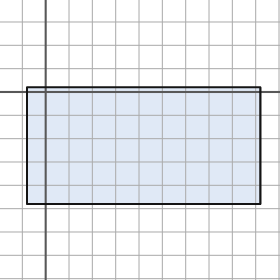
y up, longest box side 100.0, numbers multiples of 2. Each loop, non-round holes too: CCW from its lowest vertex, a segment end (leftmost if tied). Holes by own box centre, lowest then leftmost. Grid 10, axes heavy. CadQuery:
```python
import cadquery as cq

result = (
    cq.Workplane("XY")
    .moveTo(-8.0, -48.0)
    .lineTo(92.0, -48.0)
    .lineTo(92.0, 2.0)
    .lineTo(-8.0, 2.0)
    .close()
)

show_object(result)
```